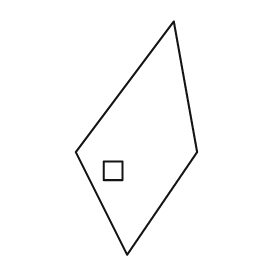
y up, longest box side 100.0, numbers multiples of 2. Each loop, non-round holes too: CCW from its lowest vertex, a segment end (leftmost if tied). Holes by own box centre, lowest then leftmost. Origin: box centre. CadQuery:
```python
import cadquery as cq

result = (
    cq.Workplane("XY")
    .moveTo(-4.0, -50.0)
    .lineTo(26.0, -6.0)
    .lineTo(16.0, 50.0)
    .lineTo(-26.0, -6.0)
    .close()
    .moveTo(-14.0, -18.0)
    .lineTo(-6.0, -18.0)
    .lineTo(-6.0, -10.0)
    .lineTo(-14.0, -10.0)
    .close()
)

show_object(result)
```